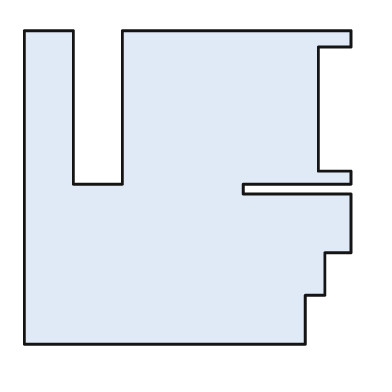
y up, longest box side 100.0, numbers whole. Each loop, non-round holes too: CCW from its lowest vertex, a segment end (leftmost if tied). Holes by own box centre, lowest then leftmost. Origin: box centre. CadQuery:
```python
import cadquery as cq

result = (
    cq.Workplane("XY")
    .moveTo(-50.0, -48.0)
    .lineTo(36.0, -48.0)
    .lineTo(36.0, -33.0)
    .lineTo(42.0, -33.0)
    .lineTo(42.0, -20.0)
    .lineTo(50.0, -20.0)
    .lineTo(50.0, -2.0)
    .lineTo(17.0, -2.0)
    .lineTo(17.0, 1.0)
    .lineTo(50.0, 1.0)
    .lineTo(50.0, 5.0)
    .lineTo(40.0, 5.0)
    .lineTo(40.0, 43.0)
    .lineTo(50.0, 43.0)
    .lineTo(50.0, 48.0)
    .lineTo(-20.0, 48.0)
    .lineTo(-20.0, 1.0)
    .lineTo(-35.0, 1.0)
    .lineTo(-35.0, 48.0)
    .lineTo(-50.0, 48.0)
    .close()
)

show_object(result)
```